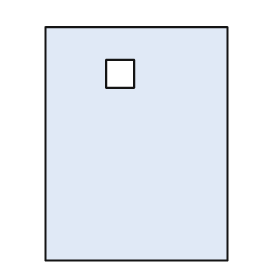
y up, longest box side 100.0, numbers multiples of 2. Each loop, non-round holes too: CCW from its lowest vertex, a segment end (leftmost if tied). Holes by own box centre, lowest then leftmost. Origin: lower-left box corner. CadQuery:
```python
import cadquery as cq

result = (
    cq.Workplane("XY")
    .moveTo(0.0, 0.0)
    .lineTo(78.0, 0.0)
    .lineTo(78.0, 100.0)
    .lineTo(0.0, 100.0)
    .close()
    .moveTo(26.0, 74.0)
    .lineTo(38.0, 74.0)
    .lineTo(38.0, 86.0)
    .lineTo(26.0, 86.0)
    .close()
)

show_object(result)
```